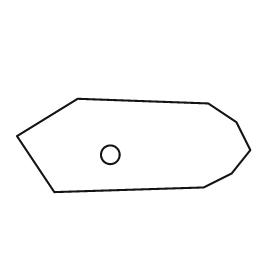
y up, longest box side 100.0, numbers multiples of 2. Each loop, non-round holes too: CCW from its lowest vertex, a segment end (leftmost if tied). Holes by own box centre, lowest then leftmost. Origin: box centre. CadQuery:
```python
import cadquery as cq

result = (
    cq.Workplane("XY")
    .moveTo(-34.0, -20.0)
    .lineTo(30.0, -18.0)
    .lineTo(42.0, -12.0)
    .lineTo(50.0, -2.0)
    .lineTo(44.0, 10.0)
    .lineTo(32.0, 18.0)
    .lineTo(-24.0, 20.0)
    .lineTo(-50.0, 4.0)
    .close()
    .moveTo(-10.0, -4.0)
    .circle(4.0)
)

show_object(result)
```